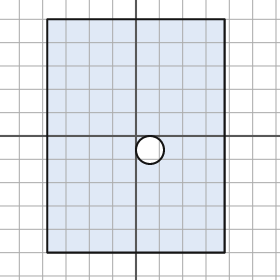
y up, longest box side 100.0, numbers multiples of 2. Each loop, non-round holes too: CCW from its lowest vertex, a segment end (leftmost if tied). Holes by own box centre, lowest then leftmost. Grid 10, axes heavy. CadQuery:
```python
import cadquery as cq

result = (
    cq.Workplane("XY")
    .moveTo(-38.0, -50.0)
    .lineTo(38.0, -50.0)
    .lineTo(38.0, 50.0)
    .lineTo(-38.0, 50.0)
    .close()
    .moveTo(6.0, -6.0)
    .circle(6.0)
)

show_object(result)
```